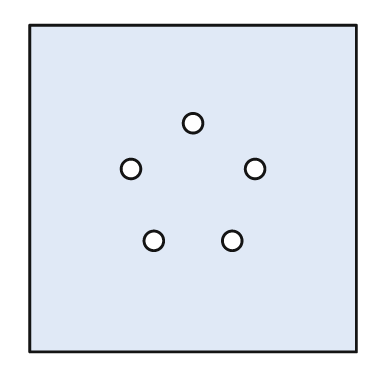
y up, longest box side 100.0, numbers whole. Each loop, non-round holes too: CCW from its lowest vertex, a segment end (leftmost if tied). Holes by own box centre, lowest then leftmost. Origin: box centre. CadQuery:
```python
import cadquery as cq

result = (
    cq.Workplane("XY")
    .moveTo(-50.0, -50.0)
    .lineTo(50.0, -50.0)
    .lineTo(50.0, 50.0)
    .lineTo(-50.0, 50.0)
    .close()
    .moveTo(-12.0, -16.0)
    .circle(3.0)
    .moveTo(12.0, -16.0)
    .circle(3.0)
    .moveTo(-19.0, 6.0)
    .circle(3.0)
    .moveTo(19.0, 6.0)
    .circle(3.0)
    .moveTo(0.0, 20.0)
    .circle(3.0)
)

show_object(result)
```